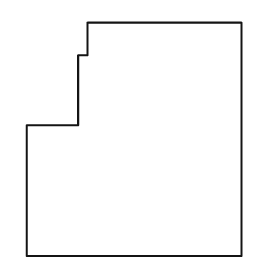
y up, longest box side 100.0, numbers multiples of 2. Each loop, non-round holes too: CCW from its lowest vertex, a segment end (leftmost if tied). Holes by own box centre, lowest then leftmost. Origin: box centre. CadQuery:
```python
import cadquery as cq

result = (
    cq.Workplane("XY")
    .moveTo(-46.0, -50.0)
    .lineTo(46.0, -50.0)
    .lineTo(46.0, 50.0)
    .lineTo(-20.0, 50.0)
    .lineTo(-20.0, 36.0)
    .lineTo(-24.0, 36.0)
    .lineTo(-24.0, 6.0)
    .lineTo(-46.0, 6.0)
    .close()
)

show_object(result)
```